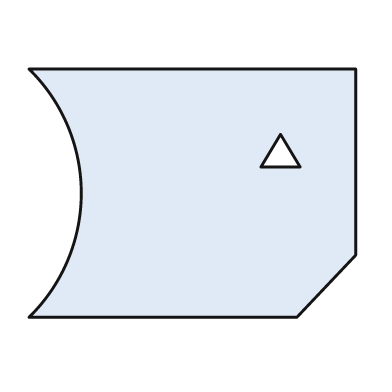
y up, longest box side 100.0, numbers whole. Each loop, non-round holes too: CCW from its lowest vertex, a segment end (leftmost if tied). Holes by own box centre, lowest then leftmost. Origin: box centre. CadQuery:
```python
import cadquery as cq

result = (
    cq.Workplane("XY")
    .moveTo(-50.0, -38.0)
    .lineTo(32.0, -38.0)
    .lineTo(50.0, -19.0)
    .lineTo(50.0, 38.0)
    .lineTo(-50.0, 38.0)
    .threePointArc((-34.0, 0.0), (-50.0, -38.0))
    .close()
    .moveTo(21.0, 8.0)
    .lineTo(33.0, 8.0)
    .lineTo(27.0, 18.0)
    .close()
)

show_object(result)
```